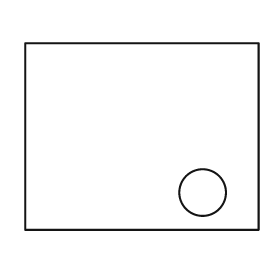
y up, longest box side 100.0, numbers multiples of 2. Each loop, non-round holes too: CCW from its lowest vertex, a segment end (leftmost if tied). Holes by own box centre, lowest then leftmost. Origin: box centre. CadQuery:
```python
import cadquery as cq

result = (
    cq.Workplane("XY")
    .moveTo(-50.0, -40.0)
    .lineTo(50.0, -40.0)
    .lineTo(50.0, 40.0)
    .lineTo(-50.0, 40.0)
    .close()
    .moveTo(26.0, -24.0)
    .circle(10.0)
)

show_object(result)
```